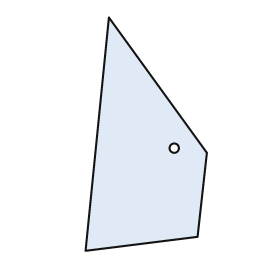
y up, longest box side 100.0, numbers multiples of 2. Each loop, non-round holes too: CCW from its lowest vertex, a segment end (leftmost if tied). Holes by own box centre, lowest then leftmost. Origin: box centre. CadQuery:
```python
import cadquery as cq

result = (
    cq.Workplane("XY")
    .moveTo(-26.0, -50.0)
    .lineTo(22.0, -44.0)
    .lineTo(26.0, -8.0)
    .lineTo(-16.0, 50.0)
    .close()
    .moveTo(12.0, -6.0)
    .circle(2.0)
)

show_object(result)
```